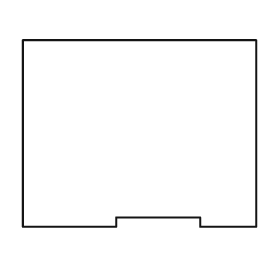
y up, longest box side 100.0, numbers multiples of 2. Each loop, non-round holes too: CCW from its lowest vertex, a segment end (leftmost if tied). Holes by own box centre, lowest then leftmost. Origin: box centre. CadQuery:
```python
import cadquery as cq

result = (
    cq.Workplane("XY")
    .moveTo(-50.0, -40.0)
    .lineTo(-10.0, -40.0)
    .lineTo(-10.0, -36.0)
    .lineTo(26.0, -36.0)
    .lineTo(26.0, -40.0)
    .lineTo(50.0, -40.0)
    .lineTo(50.0, 40.0)
    .lineTo(-50.0, 40.0)
    .close()
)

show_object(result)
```